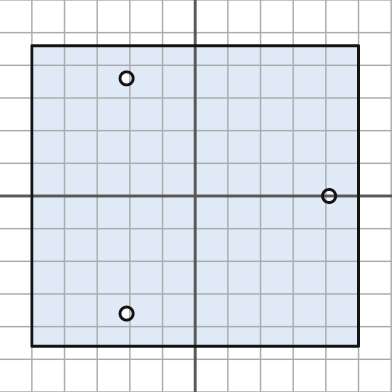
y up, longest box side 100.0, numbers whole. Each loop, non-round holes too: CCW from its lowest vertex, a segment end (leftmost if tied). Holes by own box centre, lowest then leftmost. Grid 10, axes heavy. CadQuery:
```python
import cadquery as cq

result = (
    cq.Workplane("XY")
    .moveTo(-50.0, -46.0)
    .lineTo(50.0, -46.0)
    .lineTo(50.0, 46.0)
    .lineTo(-50.0, 46.0)
    .close()
    .moveTo(-21.0, -36.0)
    .circle(2.0)
    .moveTo(41.0, 0.0)
    .circle(2.0)
    .moveTo(-21.0, 36.0)
    .circle(2.0)
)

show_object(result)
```